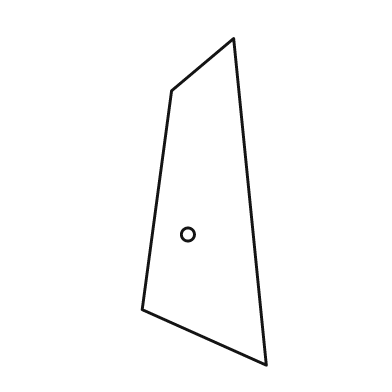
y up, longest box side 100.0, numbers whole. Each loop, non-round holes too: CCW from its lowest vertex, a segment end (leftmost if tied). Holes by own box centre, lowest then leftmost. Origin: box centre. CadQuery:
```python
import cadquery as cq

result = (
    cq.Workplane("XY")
    .moveTo(19.0, -50.0)
    .lineTo(9.0, 50.0)
    .lineTo(-10.0, 34.0)
    .lineTo(-19.0, -33.0)
    .close()
    .moveTo(-5.0, -10.0)
    .circle(2.0)
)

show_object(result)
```